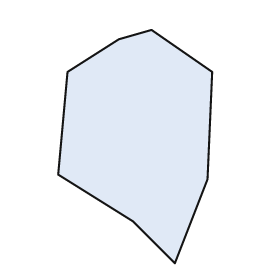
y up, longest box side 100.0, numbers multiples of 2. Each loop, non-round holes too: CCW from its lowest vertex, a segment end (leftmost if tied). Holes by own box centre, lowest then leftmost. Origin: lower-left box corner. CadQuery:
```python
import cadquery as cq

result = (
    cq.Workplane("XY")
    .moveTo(50.0, 0.0)
    .lineTo(64.0, 36.0)
    .lineTo(66.0, 82.0)
    .lineTo(40.0, 100.0)
    .lineTo(26.0, 96.0)
    .lineTo(4.0, 82.0)
    .lineTo(0.0, 38.0)
    .lineTo(32.0, 18.0)
    .close()
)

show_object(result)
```